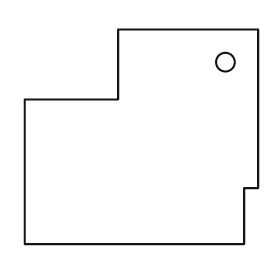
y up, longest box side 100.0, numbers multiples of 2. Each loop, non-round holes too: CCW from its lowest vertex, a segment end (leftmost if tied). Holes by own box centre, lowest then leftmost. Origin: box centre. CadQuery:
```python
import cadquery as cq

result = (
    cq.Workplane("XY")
    .moveTo(-50.0, -46.0)
    .lineTo(44.0, -46.0)
    .lineTo(44.0, -22.0)
    .lineTo(50.0, -22.0)
    .lineTo(50.0, 46.0)
    .lineTo(-10.0, 46.0)
    .lineTo(-10.0, 16.0)
    .lineTo(-50.0, 16.0)
    .close()
    .moveTo(36.0, 32.0)
    .circle(4.0)
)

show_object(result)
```